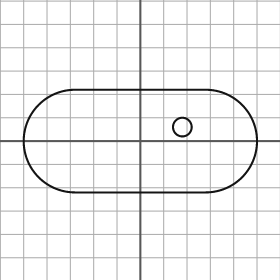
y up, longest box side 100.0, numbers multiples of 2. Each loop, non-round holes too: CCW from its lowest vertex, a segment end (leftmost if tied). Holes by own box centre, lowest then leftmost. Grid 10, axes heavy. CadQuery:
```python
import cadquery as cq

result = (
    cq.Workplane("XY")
    .moveTo(-28.0, -22.0)
    .lineTo(28.0, -22.0)
    .threePointArc((50.0, 0.0), (28.0, 22.0))
    .lineTo(-28.0, 22.0)
    .threePointArc((-50.0, 0.0), (-28.0, -22.0))
    .close()
    .moveTo(18.0, 6.0)
    .circle(4.0)
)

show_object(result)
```